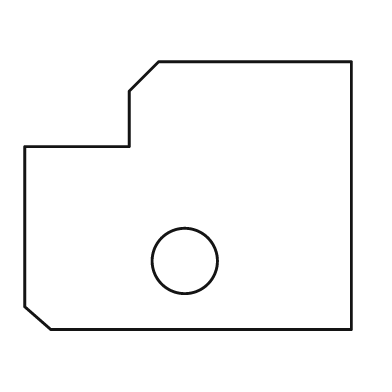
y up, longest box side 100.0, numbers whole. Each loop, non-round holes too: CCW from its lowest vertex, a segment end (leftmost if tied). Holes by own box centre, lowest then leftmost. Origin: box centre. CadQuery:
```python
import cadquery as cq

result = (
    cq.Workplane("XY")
    .moveTo(-42.0, -41.0)
    .lineTo(50.0, -41.0)
    .lineTo(50.0, 41.0)
    .lineTo(-9.0, 41.0)
    .lineTo(-18.0, 32.0)
    .lineTo(-18.0, 15.0)
    .lineTo(-50.0, 15.0)
    .lineTo(-50.0, -34.0)
    .close()
    .moveTo(-1.0, -20.0)
    .circle(10.0)
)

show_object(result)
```